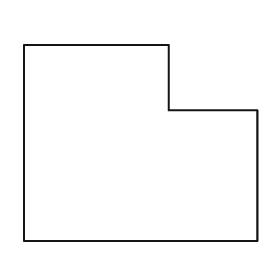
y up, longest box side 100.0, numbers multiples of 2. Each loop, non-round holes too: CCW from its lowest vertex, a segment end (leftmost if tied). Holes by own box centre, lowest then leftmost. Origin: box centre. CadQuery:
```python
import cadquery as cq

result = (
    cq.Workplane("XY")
    .moveTo(-50.0, -42.0)
    .lineTo(50.0, -42.0)
    .lineTo(50.0, 14.0)
    .lineTo(12.0, 14.0)
    .lineTo(12.0, 42.0)
    .lineTo(-50.0, 42.0)
    .close()
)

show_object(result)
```